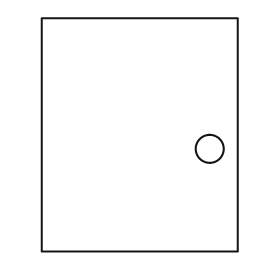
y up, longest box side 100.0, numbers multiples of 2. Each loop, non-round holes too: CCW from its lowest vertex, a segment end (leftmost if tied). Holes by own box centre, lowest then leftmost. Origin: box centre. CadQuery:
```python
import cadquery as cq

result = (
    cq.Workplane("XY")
    .moveTo(-42.0, -50.0)
    .lineTo(42.0, -50.0)
    .lineTo(42.0, 50.0)
    .lineTo(-42.0, 50.0)
    .close()
    .moveTo(30.0, -6.0)
    .circle(6.0)
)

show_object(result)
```